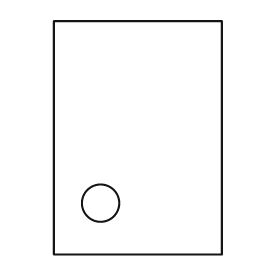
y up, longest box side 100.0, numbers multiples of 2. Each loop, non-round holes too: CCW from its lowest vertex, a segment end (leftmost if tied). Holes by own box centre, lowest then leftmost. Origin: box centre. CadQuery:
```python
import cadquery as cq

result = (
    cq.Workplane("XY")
    .moveTo(-36.0, -50.0)
    .lineTo(36.0, -50.0)
    .lineTo(36.0, 50.0)
    .lineTo(-36.0, 50.0)
    .close()
    .moveTo(-16.0, -28.0)
    .circle(8.0)
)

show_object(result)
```